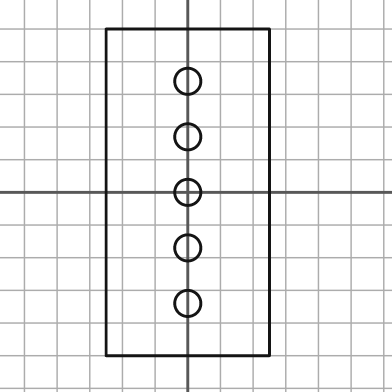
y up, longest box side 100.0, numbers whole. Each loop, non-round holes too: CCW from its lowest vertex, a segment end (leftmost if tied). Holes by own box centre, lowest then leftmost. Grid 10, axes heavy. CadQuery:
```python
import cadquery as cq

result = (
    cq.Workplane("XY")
    .moveTo(-25.0, -50.0)
    .lineTo(25.0, -50.0)
    .lineTo(25.0, 50.0)
    .lineTo(-25.0, 50.0)
    .close()
    .moveTo(0.0, -34.0)
    .circle(4.0)
    .moveTo(0.0, -17.0)
    .circle(4.0)
    .moveTo(0.0, 0.0)
    .circle(4.0)
    .moveTo(0.0, 17.0)
    .circle(4.0)
    .moveTo(0.0, 34.0)
    .circle(4.0)
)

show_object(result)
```